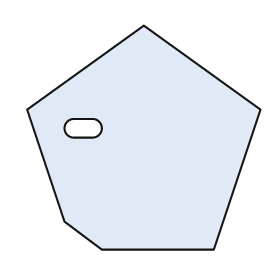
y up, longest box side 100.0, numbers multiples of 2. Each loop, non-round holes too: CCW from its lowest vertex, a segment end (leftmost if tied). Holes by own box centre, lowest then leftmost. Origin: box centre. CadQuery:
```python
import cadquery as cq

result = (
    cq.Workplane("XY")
    .moveTo(-18.0, -48.0)
    .lineTo(30.0, -48.0)
    .lineTo(50.0, 12.0)
    .lineTo(0.0, 48.0)
    .lineTo(-50.0, 12.0)
    .lineTo(-34.0, -36.0)
    .close()
    .moveTo(-30.0, 0.0)
    .lineTo(-22.0, 0.0)
    .threePointArc((-18.0, 4.0), (-22.0, 8.0))
    .lineTo(-30.0, 8.0)
    .threePointArc((-34.0, 4.0), (-30.0, 0.0))
    .close()
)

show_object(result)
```